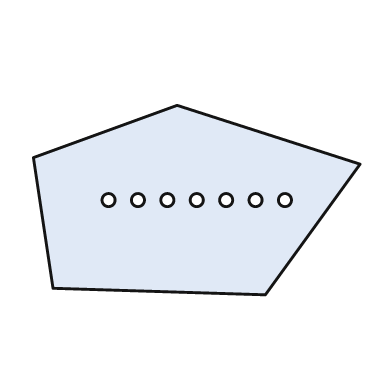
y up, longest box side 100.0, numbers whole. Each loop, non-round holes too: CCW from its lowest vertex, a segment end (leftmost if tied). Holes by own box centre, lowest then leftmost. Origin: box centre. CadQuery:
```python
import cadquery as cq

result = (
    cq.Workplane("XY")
    .moveTo(21.0, -29.0)
    .lineTo(50.0, 11.0)
    .lineTo(-6.0, 29.0)
    .lineTo(-50.0, 13.0)
    .lineTo(-44.0, -27.0)
    .close()
    .moveTo(-27.0, 0.0)
    .circle(2.0)
    .moveTo(-18.0, 0.0)
    .circle(2.0)
    .moveTo(-9.0, 0.0)
    .circle(2.0)
    .moveTo(0.0, 0.0)
    .circle(2.0)
    .moveTo(9.0, 0.0)
    .circle(2.0)
    .moveTo(18.0, 0.0)
    .circle(2.0)
    .moveTo(27.0, 0.0)
    .circle(2.0)
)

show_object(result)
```